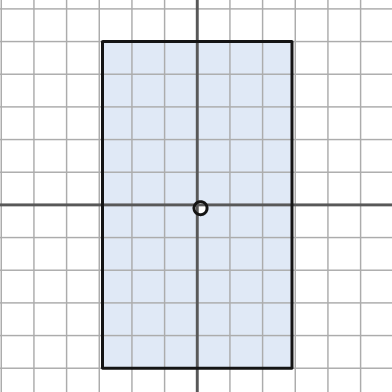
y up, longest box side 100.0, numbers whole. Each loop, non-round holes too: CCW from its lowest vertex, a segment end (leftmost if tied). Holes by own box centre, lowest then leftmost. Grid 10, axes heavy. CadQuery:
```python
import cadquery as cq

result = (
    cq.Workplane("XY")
    .moveTo(-29.0, -50.0)
    .lineTo(29.0, -50.0)
    .lineTo(29.0, 50.0)
    .lineTo(-29.0, 50.0)
    .close()
    .moveTo(1.0, -1.0)
    .circle(2.0)
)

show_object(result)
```